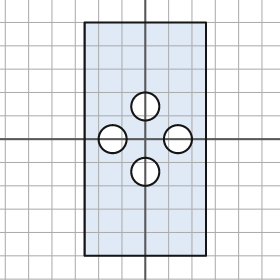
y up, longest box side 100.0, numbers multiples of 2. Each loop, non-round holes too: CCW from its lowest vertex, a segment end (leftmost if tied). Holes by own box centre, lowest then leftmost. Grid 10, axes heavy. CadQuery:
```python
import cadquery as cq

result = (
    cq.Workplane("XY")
    .moveTo(-26.0, -50.0)
    .lineTo(26.0, -50.0)
    .lineTo(26.0, 50.0)
    .lineTo(-26.0, 50.0)
    .close()
    .moveTo(0.0, -14.0)
    .circle(6.0)
    .moveTo(-14.0, 0.0)
    .circle(6.0)
    .moveTo(14.0, 0.0)
    .circle(6.0)
    .moveTo(0.0, 14.0)
    .circle(6.0)
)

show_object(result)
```